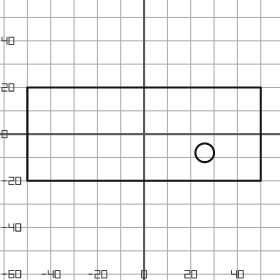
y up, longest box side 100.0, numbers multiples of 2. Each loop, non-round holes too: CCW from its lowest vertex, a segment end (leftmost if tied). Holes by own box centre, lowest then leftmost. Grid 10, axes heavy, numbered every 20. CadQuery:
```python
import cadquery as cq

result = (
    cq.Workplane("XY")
    .moveTo(-50.0, -20.0)
    .lineTo(50.0, -20.0)
    .lineTo(50.0, 20.0)
    .lineTo(-50.0, 20.0)
    .close()
    .moveTo(26.0, -8.0)
    .circle(4.0)
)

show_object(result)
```